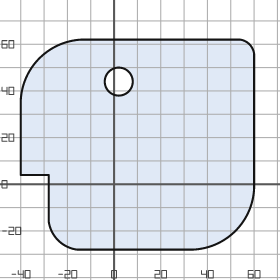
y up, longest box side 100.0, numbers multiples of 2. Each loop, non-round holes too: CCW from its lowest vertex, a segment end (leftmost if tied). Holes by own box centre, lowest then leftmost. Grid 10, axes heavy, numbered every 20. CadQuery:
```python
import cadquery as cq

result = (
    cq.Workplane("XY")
    .moveTo(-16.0, -28.0)
    .lineTo(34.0, -28.0)
    .threePointArc((52.0, -20.0), (60.0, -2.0))
    .lineTo(60.0, 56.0)
    .threePointArc((58.0, 60.0), (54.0, 62.0))
    .lineTo(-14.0, 62.0)
    .threePointArc((-32.0, 54.0), (-40.0, 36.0))
    .lineTo(-40.0, 4.0)
    .lineTo(-28.0, 4.0)
    .lineTo(-28.0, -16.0)
    .threePointArc((-24.0, -24.0), (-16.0, -28.0))
    .close()
    .moveTo(2.0, 44.0)
    .circle(6.0)
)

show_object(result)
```